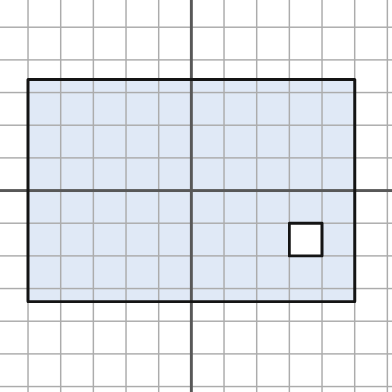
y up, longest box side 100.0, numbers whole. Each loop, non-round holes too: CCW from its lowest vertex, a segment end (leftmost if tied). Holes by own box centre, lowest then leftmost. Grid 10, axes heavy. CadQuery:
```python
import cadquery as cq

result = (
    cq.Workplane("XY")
    .moveTo(-50.0, -34.0)
    .lineTo(50.0, -34.0)
    .lineTo(50.0, 34.0)
    .lineTo(-50.0, 34.0)
    .close()
    .moveTo(30.0, -20.0)
    .lineTo(40.0, -20.0)
    .lineTo(40.0, -10.0)
    .lineTo(30.0, -10.0)
    .close()
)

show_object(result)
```